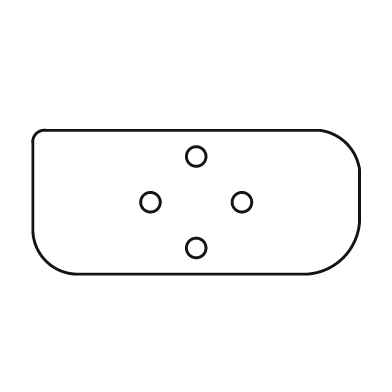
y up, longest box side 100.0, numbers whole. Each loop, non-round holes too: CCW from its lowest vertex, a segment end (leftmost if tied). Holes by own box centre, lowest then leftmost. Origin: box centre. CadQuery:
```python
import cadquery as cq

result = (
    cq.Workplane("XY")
    .moveTo(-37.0, -22.0)
    .lineTo(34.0, -22.0)
    .threePointArc((45.0, -17.0), (50.0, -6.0))
    .lineTo(50.0, 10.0)
    .threePointArc((46.0, 18.0), (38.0, 22.0))
    .lineTo(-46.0, 22.0)
    .threePointArc((-49.0, 21.0), (-50.0, 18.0))
    .lineTo(-50.0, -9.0)
    .threePointArc((-46.0, -18.0), (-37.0, -22.0))
    .close()
    .moveTo(0.0, -14.0)
    .circle(3.0)
    .moveTo(-14.0, 0.0)
    .circle(3.0)
    .moveTo(14.0, 0.0)
    .circle(3.0)
    .moveTo(0.0, 14.0)
    .circle(3.0)
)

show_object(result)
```